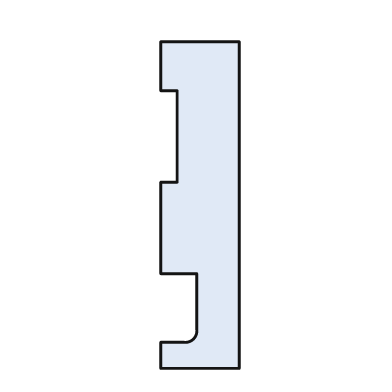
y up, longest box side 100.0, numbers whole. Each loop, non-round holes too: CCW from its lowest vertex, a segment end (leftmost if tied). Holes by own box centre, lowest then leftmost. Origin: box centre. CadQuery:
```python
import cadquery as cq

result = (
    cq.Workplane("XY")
    .moveTo(-12.0, -50.0)
    .lineTo(12.0, -50.0)
    .lineTo(12.0, 50.0)
    .lineTo(-12.0, 50.0)
    .lineTo(-12.0, 35.0)
    .lineTo(-7.0, 35.0)
    .lineTo(-7.0, 7.0)
    .lineTo(-12.0, 7.0)
    .lineTo(-12.0, -21.0)
    .lineTo(-1.0, -21.0)
    .lineTo(-1.0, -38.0)
    .threePointArc((-2.0, -41.0), (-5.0, -42.0))
    .lineTo(-12.0, -42.0)
    .close()
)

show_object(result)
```